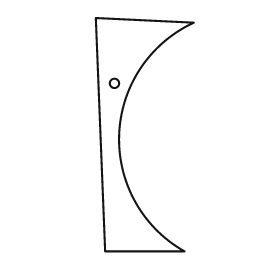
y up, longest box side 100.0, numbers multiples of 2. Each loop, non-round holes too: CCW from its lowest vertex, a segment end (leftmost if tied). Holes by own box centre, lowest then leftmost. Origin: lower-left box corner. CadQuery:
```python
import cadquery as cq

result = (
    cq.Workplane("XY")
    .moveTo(4.0, 0.0)
    .lineTo(38.0, 0.0)
    .threePointArc((10.0, 50.0), (42.0, 98.0))
    .lineTo(0.0, 100.0)
    .close()
    .moveTo(8.0, 72.0)
    .circle(2.0)
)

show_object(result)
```